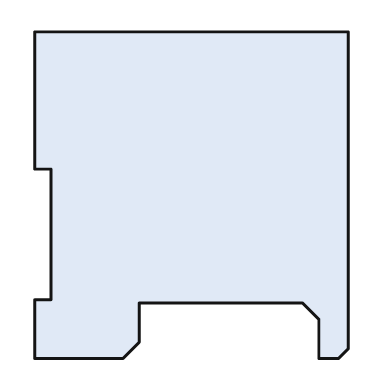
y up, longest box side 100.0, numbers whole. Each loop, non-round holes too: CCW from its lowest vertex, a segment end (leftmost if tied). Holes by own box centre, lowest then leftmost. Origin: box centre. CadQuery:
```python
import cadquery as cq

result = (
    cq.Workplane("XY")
    .moveTo(-48.0, -50.0)
    .lineTo(-21.0, -50.0)
    .lineTo(-16.0, -45.0)
    .lineTo(-16.0, -33.0)
    .lineTo(34.0, -33.0)
    .lineTo(39.0, -38.0)
    .lineTo(39.0, -50.0)
    .lineTo(45.0, -50.0)
    .lineTo(48.0, -47.0)
    .lineTo(48.0, 50.0)
    .lineTo(-48.0, 50.0)
    .lineTo(-48.0, 8.0)
    .lineTo(-43.0, 8.0)
    .lineTo(-43.0, -32.0)
    .lineTo(-48.0, -32.0)
    .close()
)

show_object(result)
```